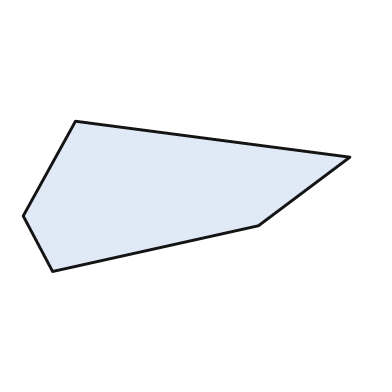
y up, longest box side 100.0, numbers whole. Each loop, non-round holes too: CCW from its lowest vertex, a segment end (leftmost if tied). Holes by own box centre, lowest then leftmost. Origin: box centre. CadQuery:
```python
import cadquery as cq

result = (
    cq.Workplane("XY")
    .moveTo(-41.0, -23.0)
    .lineTo(22.0, -9.0)
    .lineTo(50.0, 12.0)
    .lineTo(-34.0, 23.0)
    .lineTo(-50.0, -6.0)
    .close()
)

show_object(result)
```